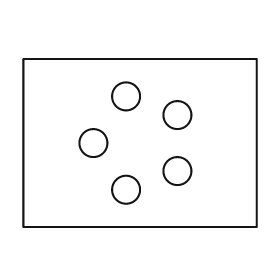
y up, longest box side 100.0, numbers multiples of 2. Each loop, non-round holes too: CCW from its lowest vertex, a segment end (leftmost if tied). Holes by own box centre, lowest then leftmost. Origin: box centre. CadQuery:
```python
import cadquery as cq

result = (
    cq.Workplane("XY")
    .moveTo(-50.0, -36.0)
    .lineTo(50.0, -36.0)
    .lineTo(50.0, 36.0)
    .lineTo(-50.0, 36.0)
    .close()
    .moveTo(-6.0, -20.0)
    .circle(6.0)
    .moveTo(16.0, -12.0)
    .circle(6.0)
    .moveTo(-20.0, 0.0)
    .circle(6.0)
    .moveTo(16.0, 12.0)
    .circle(6.0)
    .moveTo(-6.0, 20.0)
    .circle(6.0)
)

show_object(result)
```